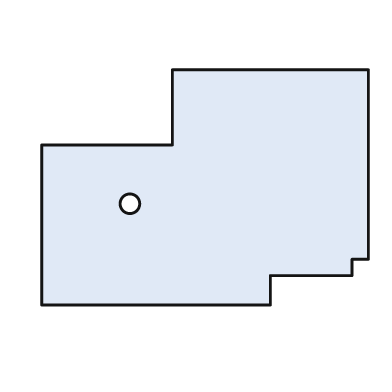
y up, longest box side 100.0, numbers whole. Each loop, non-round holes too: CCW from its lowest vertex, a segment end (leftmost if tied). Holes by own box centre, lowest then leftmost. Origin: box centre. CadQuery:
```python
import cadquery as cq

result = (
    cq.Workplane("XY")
    .moveTo(-50.0, -36.0)
    .lineTo(20.0, -36.0)
    .lineTo(20.0, -27.0)
    .lineTo(45.0, -27.0)
    .lineTo(45.0, -22.0)
    .lineTo(50.0, -22.0)
    .lineTo(50.0, 36.0)
    .lineTo(-10.0, 36.0)
    .lineTo(-10.0, 13.0)
    .lineTo(-50.0, 13.0)
    .close()
    .moveTo(-23.0, -5.0)
    .circle(3.0)
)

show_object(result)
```